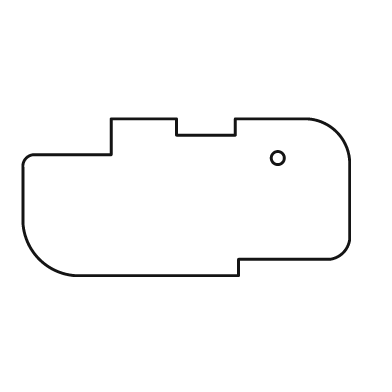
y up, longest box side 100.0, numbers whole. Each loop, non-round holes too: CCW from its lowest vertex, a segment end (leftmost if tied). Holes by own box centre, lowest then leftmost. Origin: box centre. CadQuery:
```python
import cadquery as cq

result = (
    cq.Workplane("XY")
    .moveTo(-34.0, -24.0)
    .lineTo(16.0, -24.0)
    .lineTo(16.0, -19.0)
    .lineTo(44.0, -19.0)
    .threePointArc((48.0, -17.0), (50.0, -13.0))
    .lineTo(50.0, 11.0)
    .threePointArc((46.0, 20.0), (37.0, 24.0))
    .lineTo(15.0, 24.0)
    .lineTo(15.0, 19.0)
    .lineTo(-3.0, 19.0)
    .lineTo(-3.0, 24.0)
    .lineTo(-23.0, 24.0)
    .lineTo(-23.0, 13.0)
    .lineTo(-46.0, 13.0)
    .threePointArc((-49.0, 12.0), (-50.0, 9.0))
    .lineTo(-50.0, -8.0)
    .threePointArc((-45.0, -19.0), (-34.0, -24.0))
    .close()
    .moveTo(28.0, 12.0)
    .circle(2.0)
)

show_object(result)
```